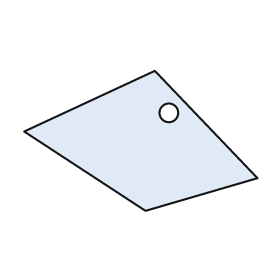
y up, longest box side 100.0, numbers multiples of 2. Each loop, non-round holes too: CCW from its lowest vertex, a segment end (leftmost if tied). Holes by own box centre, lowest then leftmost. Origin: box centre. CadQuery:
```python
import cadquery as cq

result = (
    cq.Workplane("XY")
    .moveTo(2.0, -30.0)
    .lineTo(50.0, -16.0)
    .lineTo(6.0, 30.0)
    .lineTo(-50.0, 4.0)
    .close()
    .moveTo(12.0, 12.0)
    .circle(4.0)
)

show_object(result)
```